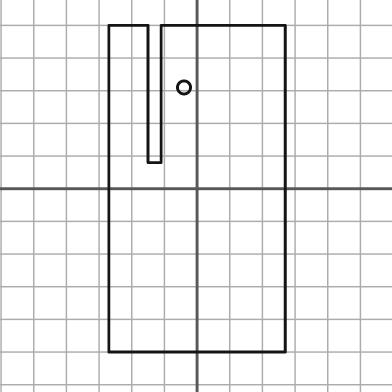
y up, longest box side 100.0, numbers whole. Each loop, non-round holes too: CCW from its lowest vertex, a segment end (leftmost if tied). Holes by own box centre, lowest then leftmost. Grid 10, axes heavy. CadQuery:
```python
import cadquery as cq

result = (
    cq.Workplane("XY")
    .moveTo(-27.0, -50.0)
    .lineTo(27.0, -50.0)
    .lineTo(27.0, 50.0)
    .lineTo(-11.0, 50.0)
    .lineTo(-11.0, 8.0)
    .lineTo(-15.0, 8.0)
    .lineTo(-15.0, 50.0)
    .lineTo(-27.0, 50.0)
    .close()
    .moveTo(-4.0, 31.0)
    .circle(2.0)
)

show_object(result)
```